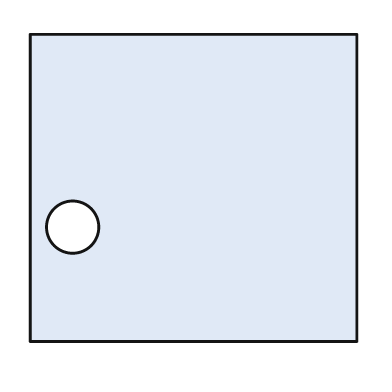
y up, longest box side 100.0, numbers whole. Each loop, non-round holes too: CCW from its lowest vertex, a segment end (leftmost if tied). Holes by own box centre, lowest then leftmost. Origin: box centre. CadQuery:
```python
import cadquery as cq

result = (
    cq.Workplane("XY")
    .moveTo(-50.0, -47.0)
    .lineTo(50.0, -47.0)
    .lineTo(50.0, 47.0)
    .lineTo(-50.0, 47.0)
    .close()
    .moveTo(-37.0, -12.0)
    .circle(8.0)
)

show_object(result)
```